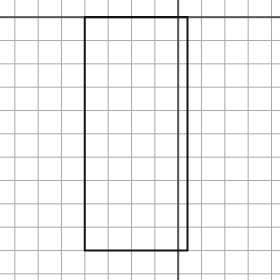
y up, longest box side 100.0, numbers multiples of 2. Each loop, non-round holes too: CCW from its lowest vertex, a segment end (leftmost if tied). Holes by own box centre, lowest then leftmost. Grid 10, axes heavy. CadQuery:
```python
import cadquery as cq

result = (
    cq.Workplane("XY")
    .moveTo(-40.0, -100.0)
    .lineTo(4.0, -100.0)
    .lineTo(4.0, 0.0)
    .lineTo(-40.0, 0.0)
    .close()
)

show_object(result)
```